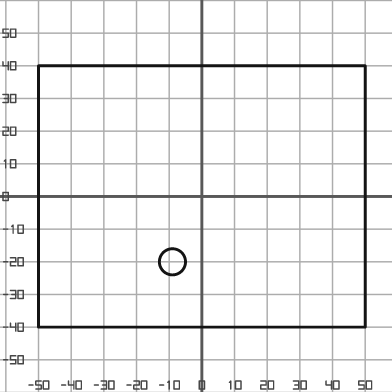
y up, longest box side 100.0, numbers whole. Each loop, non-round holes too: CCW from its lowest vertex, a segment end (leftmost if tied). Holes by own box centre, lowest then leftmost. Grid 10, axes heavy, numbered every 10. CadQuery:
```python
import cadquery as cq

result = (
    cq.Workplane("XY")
    .moveTo(-50.0, -40.0)
    .lineTo(50.0, -40.0)
    .lineTo(50.0, 40.0)
    .lineTo(-50.0, 40.0)
    .close()
    .moveTo(-9.0, -20.0)
    .circle(4.0)
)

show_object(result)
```